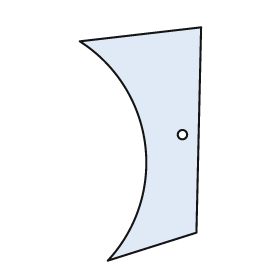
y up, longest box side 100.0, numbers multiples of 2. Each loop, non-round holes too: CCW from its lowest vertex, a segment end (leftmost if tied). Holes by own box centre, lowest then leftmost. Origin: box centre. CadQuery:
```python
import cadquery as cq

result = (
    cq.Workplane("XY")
    .moveTo(-14.0, -50.0)
    .lineTo(24.0, -38.0)
    .lineTo(26.0, 50.0)
    .lineTo(-26.0, 44.0)
    .threePointArc((2.0, 0.0), (-14.0, -50.0))
    .close()
    .moveTo(18.0, 4.0)
    .circle(2.0)
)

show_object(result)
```